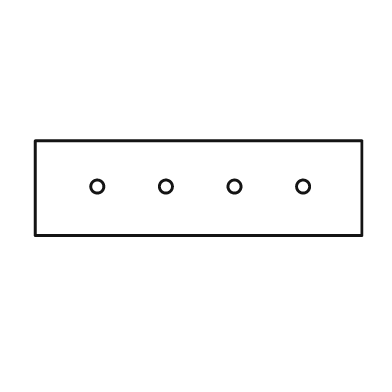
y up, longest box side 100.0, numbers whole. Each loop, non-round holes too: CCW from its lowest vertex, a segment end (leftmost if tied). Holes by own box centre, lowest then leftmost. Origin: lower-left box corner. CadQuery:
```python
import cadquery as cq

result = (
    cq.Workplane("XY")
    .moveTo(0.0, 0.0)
    .lineTo(100.0, 0.0)
    .lineTo(100.0, 29.0)
    .lineTo(0.0, 29.0)
    .close()
    .moveTo(19.0, 15.0)
    .circle(2.0)
    .moveTo(40.0, 15.0)
    .circle(2.0)
    .moveTo(61.0, 15.0)
    .circle(2.0)
    .moveTo(82.0, 15.0)
    .circle(2.0)
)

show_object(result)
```